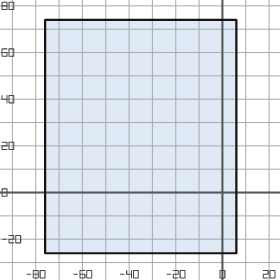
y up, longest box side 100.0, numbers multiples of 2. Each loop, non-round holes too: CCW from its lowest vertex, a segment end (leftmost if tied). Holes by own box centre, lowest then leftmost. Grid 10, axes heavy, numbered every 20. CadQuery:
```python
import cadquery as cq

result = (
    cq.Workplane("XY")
    .moveTo(-76.0, -26.0)
    .lineTo(6.0, -26.0)
    .lineTo(6.0, 74.0)
    .lineTo(-76.0, 74.0)
    .close()
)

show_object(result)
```